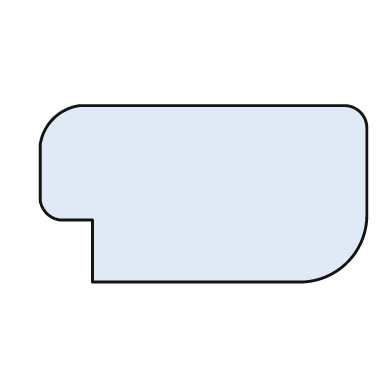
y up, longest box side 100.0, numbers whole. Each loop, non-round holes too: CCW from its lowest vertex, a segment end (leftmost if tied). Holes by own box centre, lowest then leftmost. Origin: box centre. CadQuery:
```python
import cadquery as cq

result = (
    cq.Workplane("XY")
    .moveTo(-34.0, -27.0)
    .lineTo(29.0, -27.0)
    .threePointArc((44.0, -21.0), (50.0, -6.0))
    .lineTo(50.0, 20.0)
    .threePointArc((48.0, 25.0), (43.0, 27.0))
    .lineTo(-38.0, 27.0)
    .threePointArc((-46.0, 23.0), (-50.0, 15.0))
    .lineTo(-50.0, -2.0)
    .threePointArc((-48.0, -6.0), (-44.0, -8.0))
    .lineTo(-34.0, -8.0)
    .close()
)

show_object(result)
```